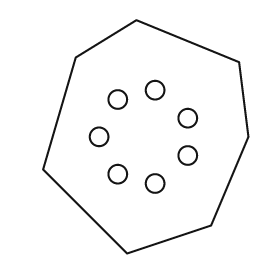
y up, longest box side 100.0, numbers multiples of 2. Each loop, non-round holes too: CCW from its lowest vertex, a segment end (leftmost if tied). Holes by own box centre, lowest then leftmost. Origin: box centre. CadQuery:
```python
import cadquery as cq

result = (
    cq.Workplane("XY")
    .moveTo(-8.0, -50.0)
    .lineTo(28.0, -38.0)
    .lineTo(44.0, 0.0)
    .lineTo(40.0, 32.0)
    .lineTo(-4.0, 50.0)
    .lineTo(-30.0, 34.0)
    .lineTo(-44.0, -14.0)
    .close()
    .moveTo(4.0, -20.0)
    .circle(4.0)
    .moveTo(-12.0, -16.0)
    .circle(4.0)
    .moveTo(18.0, -8.0)
    .circle(4.0)
    .moveTo(-20.0, 0.0)
    .circle(4.0)
    .moveTo(18.0, 8.0)
    .circle(4.0)
    .moveTo(-12.0, 16.0)
    .circle(4.0)
    .moveTo(4.0, 20.0)
    .circle(4.0)
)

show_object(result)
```